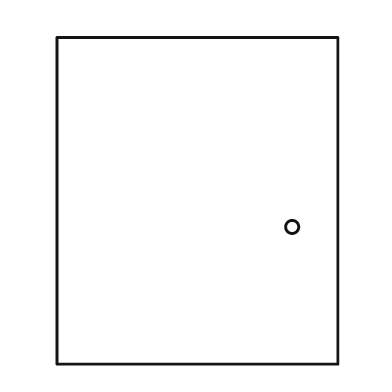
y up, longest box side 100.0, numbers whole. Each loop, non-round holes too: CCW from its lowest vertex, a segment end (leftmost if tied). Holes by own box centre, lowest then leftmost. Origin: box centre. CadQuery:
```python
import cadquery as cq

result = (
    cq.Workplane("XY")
    .moveTo(-43.0, -50.0)
    .lineTo(43.0, -50.0)
    .lineTo(43.0, 50.0)
    .lineTo(-43.0, 50.0)
    .close()
    .moveTo(29.0, -8.0)
    .circle(2.0)
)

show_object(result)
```